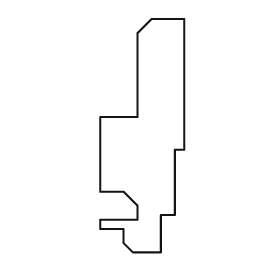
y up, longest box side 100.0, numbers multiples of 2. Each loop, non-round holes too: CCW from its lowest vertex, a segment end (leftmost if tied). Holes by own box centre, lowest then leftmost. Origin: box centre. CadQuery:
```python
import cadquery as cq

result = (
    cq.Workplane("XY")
    .moveTo(-4.0, -50.0)
    .lineTo(8.0, -50.0)
    .lineTo(8.0, -34.0)
    .lineTo(14.0, -34.0)
    .lineTo(14.0, -6.0)
    .lineTo(18.0, -6.0)
    .lineTo(18.0, 50.0)
    .lineTo(4.0, 50.0)
    .lineTo(-2.0, 44.0)
    .lineTo(-2.0, 8.0)
    .lineTo(-18.0, 8.0)
    .lineTo(-18.0, -24.0)
    .lineTo(-8.0, -24.0)
    .lineTo(-2.0, -30.0)
    .lineTo(-2.0, -36.0)
    .lineTo(-18.0, -36.0)
    .lineTo(-18.0, -40.0)
    .lineTo(-8.0, -40.0)
    .lineTo(-8.0, -46.0)
    .close()
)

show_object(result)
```